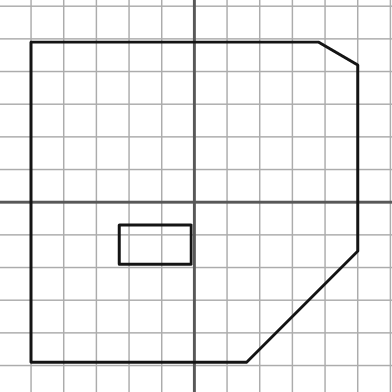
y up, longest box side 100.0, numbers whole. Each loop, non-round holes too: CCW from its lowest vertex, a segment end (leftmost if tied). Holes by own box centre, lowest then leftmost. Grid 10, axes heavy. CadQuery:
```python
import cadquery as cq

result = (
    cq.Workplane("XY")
    .moveTo(-50.0, -49.0)
    .lineTo(16.0, -49.0)
    .lineTo(50.0, -15.0)
    .lineTo(50.0, 42.0)
    .lineTo(38.0, 49.0)
    .lineTo(-50.0, 49.0)
    .close()
    .moveTo(-23.0, -19.0)
    .lineTo(-1.0, -19.0)
    .lineTo(-1.0, -7.0)
    .lineTo(-23.0, -7.0)
    .close()
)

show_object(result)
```